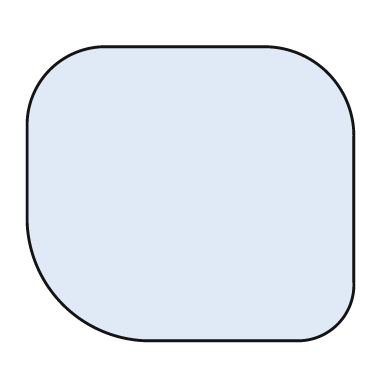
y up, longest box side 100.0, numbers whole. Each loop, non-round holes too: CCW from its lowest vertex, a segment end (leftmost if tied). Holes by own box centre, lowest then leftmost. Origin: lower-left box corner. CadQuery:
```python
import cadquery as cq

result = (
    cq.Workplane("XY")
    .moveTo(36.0, 0.0)
    .lineTo(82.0, 0.0)
    .threePointArc((95.0, 5.0), (100.0, 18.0))
    .lineTo(100.0, 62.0)
    .threePointArc((92.0, 82.0), (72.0, 90.0))
    .lineTo(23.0, 90.0)
    .threePointArc((7.0, 83.0), (0.0, 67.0))
    .lineTo(0.0, 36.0)
    .threePointArc((11.0, 11.0), (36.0, 0.0))
    .close()
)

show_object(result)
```